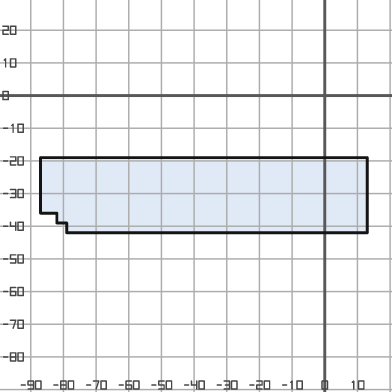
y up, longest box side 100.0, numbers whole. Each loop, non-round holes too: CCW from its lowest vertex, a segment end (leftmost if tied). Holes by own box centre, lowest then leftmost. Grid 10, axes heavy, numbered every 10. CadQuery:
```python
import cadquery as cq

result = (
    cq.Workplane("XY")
    .moveTo(-79.0, -42.0)
    .lineTo(13.0, -42.0)
    .lineTo(13.0, -19.0)
    .lineTo(-87.0, -19.0)
    .lineTo(-87.0, -36.0)
    .lineTo(-82.0, -36.0)
    .lineTo(-82.0, -39.0)
    .lineTo(-79.0, -39.0)
    .close()
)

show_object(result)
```